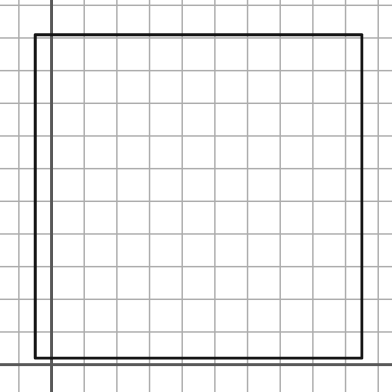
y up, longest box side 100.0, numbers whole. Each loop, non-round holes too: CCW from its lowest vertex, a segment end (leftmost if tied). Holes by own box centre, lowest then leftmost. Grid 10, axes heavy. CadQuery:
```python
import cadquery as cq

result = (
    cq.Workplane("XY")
    .moveTo(-5.0, 2.0)
    .lineTo(95.0, 2.0)
    .lineTo(95.0, 101.0)
    .lineTo(-5.0, 101.0)
    .close()
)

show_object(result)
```